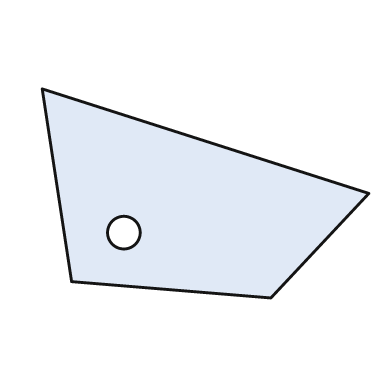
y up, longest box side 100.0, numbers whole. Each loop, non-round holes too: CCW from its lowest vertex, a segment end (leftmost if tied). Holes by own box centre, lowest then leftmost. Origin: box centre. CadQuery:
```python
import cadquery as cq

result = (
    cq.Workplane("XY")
    .moveTo(20.0, -32.0)
    .lineTo(50.0, 0.0)
    .lineTo(-50.0, 32.0)
    .lineTo(-41.0, -27.0)
    .close()
    .moveTo(-25.0, -12.0)
    .circle(5.0)
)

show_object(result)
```